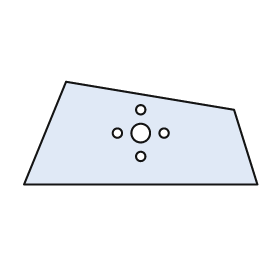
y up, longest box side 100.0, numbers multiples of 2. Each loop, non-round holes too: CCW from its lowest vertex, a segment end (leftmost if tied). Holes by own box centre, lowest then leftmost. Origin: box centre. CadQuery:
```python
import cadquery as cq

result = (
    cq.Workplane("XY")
    .moveTo(-50.0, -22.0)
    .lineTo(50.0, -22.0)
    .lineTo(40.0, 10.0)
    .lineTo(-32.0, 22.0)
    .close()
    .moveTo(0.0, -10.0)
    .circle(2.0)
    .moveTo(-10.0, 0.0)
    .circle(2.0)
    .moveTo(0.0, 0.0)
    .circle(4.0)
    .moveTo(10.0, 0.0)
    .circle(2.0)
    .moveTo(0.0, 10.0)
    .circle(2.0)
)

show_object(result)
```